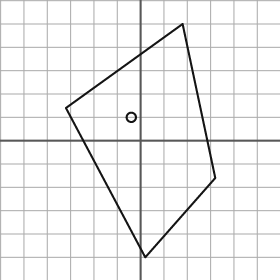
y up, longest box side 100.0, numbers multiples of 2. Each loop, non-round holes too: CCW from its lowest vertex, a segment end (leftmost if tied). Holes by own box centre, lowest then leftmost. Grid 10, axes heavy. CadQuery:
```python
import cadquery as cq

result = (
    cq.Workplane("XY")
    .moveTo(2.0, -50.0)
    .lineTo(32.0, -16.0)
    .lineTo(18.0, 50.0)
    .lineTo(-32.0, 14.0)
    .close()
    .moveTo(-4.0, 10.0)
    .circle(2.0)
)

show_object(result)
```